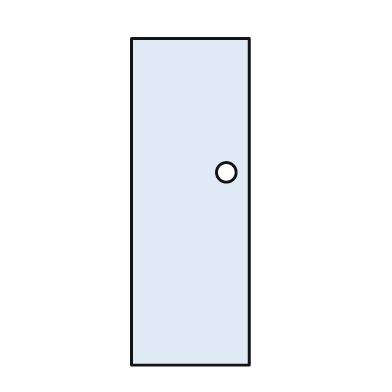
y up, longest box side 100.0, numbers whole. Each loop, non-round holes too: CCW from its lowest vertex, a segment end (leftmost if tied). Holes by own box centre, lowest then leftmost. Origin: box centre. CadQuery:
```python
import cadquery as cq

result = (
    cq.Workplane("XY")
    .moveTo(-18.0, -50.0)
    .lineTo(18.0, -50.0)
    .lineTo(18.0, 50.0)
    .lineTo(-18.0, 50.0)
    .close()
    .moveTo(11.0, 9.0)
    .circle(3.0)
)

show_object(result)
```